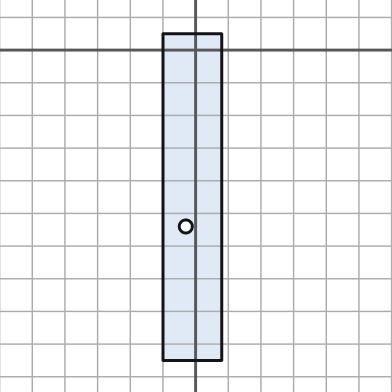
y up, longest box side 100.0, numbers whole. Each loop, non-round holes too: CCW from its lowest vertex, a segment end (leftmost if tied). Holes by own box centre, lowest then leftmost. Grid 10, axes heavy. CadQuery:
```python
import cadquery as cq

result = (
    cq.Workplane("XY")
    .moveTo(-10.0, -95.0)
    .lineTo(8.0, -95.0)
    .lineTo(8.0, 5.0)
    .lineTo(-10.0, 5.0)
    .close()
    .moveTo(-3.0, -54.0)
    .circle(2.0)
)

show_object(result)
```